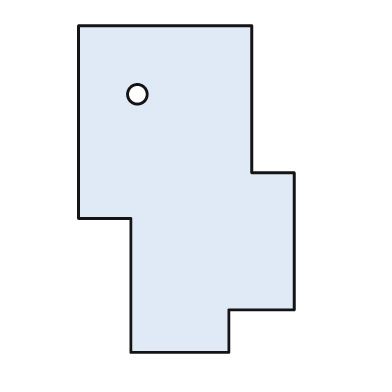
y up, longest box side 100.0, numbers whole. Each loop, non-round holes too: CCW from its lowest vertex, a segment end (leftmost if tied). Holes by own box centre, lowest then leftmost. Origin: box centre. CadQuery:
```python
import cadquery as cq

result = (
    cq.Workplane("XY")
    .moveTo(-17.0, -50.0)
    .lineTo(13.0, -50.0)
    .lineTo(13.0, -37.0)
    .lineTo(33.0, -37.0)
    .lineTo(33.0, 5.0)
    .lineTo(20.0, 5.0)
    .lineTo(20.0, 50.0)
    .lineTo(-33.0, 50.0)
    .lineTo(-33.0, -9.0)
    .lineTo(-17.0, -9.0)
    .close()
    .moveTo(-15.0, 29.0)
    .circle(3.0)
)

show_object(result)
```